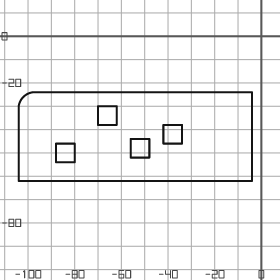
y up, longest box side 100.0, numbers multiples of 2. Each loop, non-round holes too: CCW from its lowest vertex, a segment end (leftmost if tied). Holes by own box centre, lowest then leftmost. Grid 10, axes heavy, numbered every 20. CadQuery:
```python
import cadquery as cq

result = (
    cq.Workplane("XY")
    .moveTo(-104.0, -62.0)
    .lineTo(-4.0, -62.0)
    .lineTo(-4.0, -24.0)
    .lineTo(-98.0, -24.0)
    .threePointArc((-102.0, -26.0), (-104.0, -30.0))
    .close()
    .moveTo(-88.0, -54.0)
    .lineTo(-80.0, -54.0)
    .lineTo(-80.0, -46.0)
    .lineTo(-88.0, -46.0)
    .close()
    .moveTo(-56.0, -52.0)
    .lineTo(-48.0, -52.0)
    .lineTo(-48.0, -44.0)
    .lineTo(-56.0, -44.0)
    .close()
    .moveTo(-42.0, -46.0)
    .lineTo(-34.0, -46.0)
    .lineTo(-34.0, -38.0)
    .lineTo(-42.0, -38.0)
    .close()
    .moveTo(-70.0, -38.0)
    .lineTo(-62.0, -38.0)
    .lineTo(-62.0, -30.0)
    .lineTo(-70.0, -30.0)
    .close()
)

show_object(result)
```